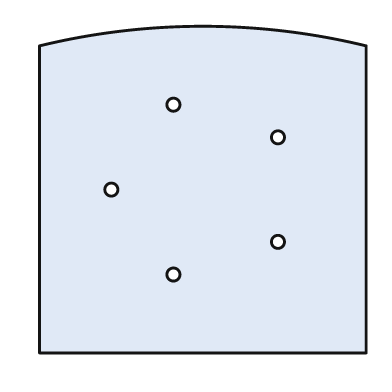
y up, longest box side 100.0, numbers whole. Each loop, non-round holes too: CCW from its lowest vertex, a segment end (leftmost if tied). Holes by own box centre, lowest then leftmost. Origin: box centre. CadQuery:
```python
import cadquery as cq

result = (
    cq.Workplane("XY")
    .moveTo(-50.0, -50.0)
    .lineTo(50.0, -50.0)
    .lineTo(50.0, 44.0)
    .threePointArc((0.0, 50.0), (-50.0, 44.0))
    .close()
    .moveTo(-9.0, -26.0)
    .circle(2.0)
    .moveTo(23.0, -16.0)
    .circle(2.0)
    .moveTo(-28.0, 0.0)
    .circle(2.0)
    .moveTo(23.0, 16.0)
    .circle(2.0)
    .moveTo(-9.0, 26.0)
    .circle(2.0)
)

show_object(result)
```